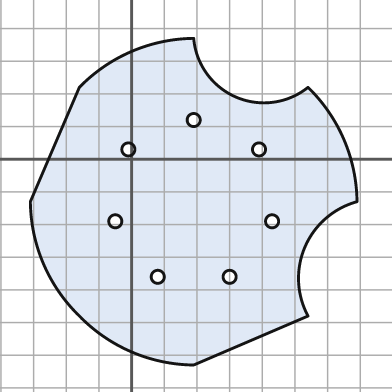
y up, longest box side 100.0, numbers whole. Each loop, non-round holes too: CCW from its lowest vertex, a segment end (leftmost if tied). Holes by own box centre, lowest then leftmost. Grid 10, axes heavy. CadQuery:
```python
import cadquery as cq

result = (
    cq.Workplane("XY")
    .moveTo(19.0, -63.0)
    .lineTo(54.0, -48.0)
    .threePointArc((53.0, -27.0), (69.0, -13.0))
    .threePointArc((65.0, 6.0), (54.0, 22.0))
    .threePointArc((32.0, 19.0), (19.0, 37.0))
    .threePointArc((0.0, 33.0), (-16.0, 22.0))
    .lineTo(-31.0, -13.0)
    .threePointArc((-27.0, -32.0), (-16.0, -48.0))
    .threePointArc((0.0, -59.0), (19.0, -63.0))
    .close()
    .moveTo(8.0, -36.0)
    .circle(2.0)
    .moveTo(30.0, -36.0)
    .circle(2.0)
    .moveTo(-5.0, -19.0)
    .circle(2.0)
    .moveTo(43.0, -19.0)
    .circle(2.0)
    .moveTo(-1.0, 3.0)
    .circle(2.0)
    .moveTo(39.0, 3.0)
    .circle(2.0)
    .moveTo(19.0, 12.0)
    .circle(2.0)
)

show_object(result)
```